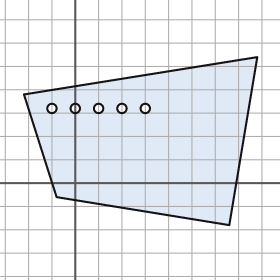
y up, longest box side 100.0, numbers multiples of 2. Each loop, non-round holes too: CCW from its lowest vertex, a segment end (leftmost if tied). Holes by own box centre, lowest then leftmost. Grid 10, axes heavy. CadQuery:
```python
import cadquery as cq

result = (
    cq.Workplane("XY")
    .moveTo(66.0, -18.0)
    .lineTo(78.0, 54.0)
    .lineTo(-22.0, 38.0)
    .lineTo(-8.0, -6.0)
    .close()
    .moveTo(-10.0, 32.0)
    .circle(2.0)
    .moveTo(0.0, 32.0)
    .circle(2.0)
    .moveTo(10.0, 32.0)
    .circle(2.0)
    .moveTo(20.0, 32.0)
    .circle(2.0)
    .moveTo(30.0, 32.0)
    .circle(2.0)
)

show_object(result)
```